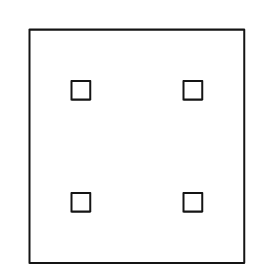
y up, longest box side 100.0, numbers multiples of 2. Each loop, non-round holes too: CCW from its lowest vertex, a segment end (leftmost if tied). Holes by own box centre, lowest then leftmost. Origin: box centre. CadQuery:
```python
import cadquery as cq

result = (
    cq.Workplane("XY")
    .moveTo(-46.0, -50.0)
    .lineTo(46.0, -50.0)
    .lineTo(46.0, 50.0)
    .lineTo(-46.0, 50.0)
    .close()
    .moveTo(-28.0, -28.0)
    .lineTo(-20.0, -28.0)
    .lineTo(-20.0, -20.0)
    .lineTo(-28.0, -20.0)
    .close()
    .moveTo(20.0, -28.0)
    .lineTo(28.0, -28.0)
    .lineTo(28.0, -20.0)
    .lineTo(20.0, -20.0)
    .close()
    .moveTo(-28.0, 20.0)
    .lineTo(-20.0, 20.0)
    .lineTo(-20.0, 28.0)
    .lineTo(-28.0, 28.0)
    .close()
    .moveTo(20.0, 20.0)
    .lineTo(28.0, 20.0)
    .lineTo(28.0, 28.0)
    .lineTo(20.0, 28.0)
    .close()
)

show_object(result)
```